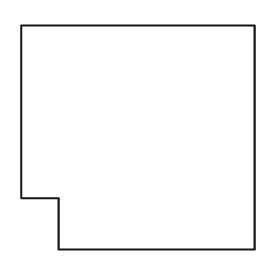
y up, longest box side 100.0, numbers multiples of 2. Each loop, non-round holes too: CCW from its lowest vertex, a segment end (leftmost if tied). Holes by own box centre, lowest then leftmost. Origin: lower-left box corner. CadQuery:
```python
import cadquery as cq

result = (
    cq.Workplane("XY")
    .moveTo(16.0, 0.0)
    .lineTo(100.0, 0.0)
    .lineTo(100.0, 96.0)
    .lineTo(0.0, 96.0)
    .lineTo(0.0, 22.0)
    .lineTo(16.0, 22.0)
    .close()
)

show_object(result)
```